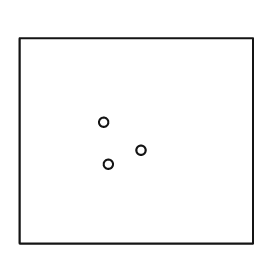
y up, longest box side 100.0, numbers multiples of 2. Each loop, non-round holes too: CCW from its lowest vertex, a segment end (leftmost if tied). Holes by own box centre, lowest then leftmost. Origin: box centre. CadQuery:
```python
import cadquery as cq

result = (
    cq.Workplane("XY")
    .moveTo(-50.0, -44.0)
    .lineTo(50.0, -44.0)
    .lineTo(50.0, 44.0)
    .lineTo(-50.0, 44.0)
    .close()
    .moveTo(-12.0, -10.0)
    .circle(2.0)
    .moveTo(2.0, -4.0)
    .circle(2.0)
    .moveTo(-14.0, 8.0)
    .circle(2.0)
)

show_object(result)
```